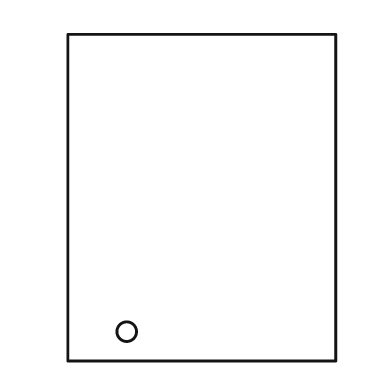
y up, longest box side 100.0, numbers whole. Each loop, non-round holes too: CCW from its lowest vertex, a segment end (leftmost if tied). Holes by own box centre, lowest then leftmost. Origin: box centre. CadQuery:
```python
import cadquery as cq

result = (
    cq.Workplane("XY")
    .moveTo(-41.0, -50.0)
    .lineTo(41.0, -50.0)
    .lineTo(41.0, 50.0)
    .lineTo(-41.0, 50.0)
    .close()
    .moveTo(-23.0, -41.0)
    .circle(3.0)
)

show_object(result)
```